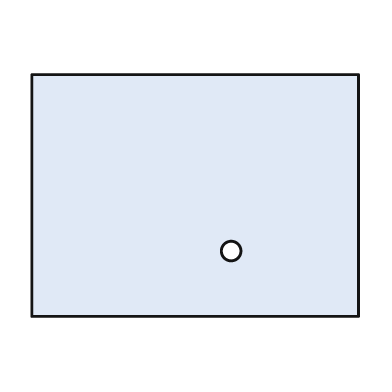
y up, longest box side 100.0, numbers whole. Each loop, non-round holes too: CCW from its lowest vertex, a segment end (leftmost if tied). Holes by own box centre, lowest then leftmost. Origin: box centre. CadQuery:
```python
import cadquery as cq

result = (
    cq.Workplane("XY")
    .moveTo(-50.0, -37.0)
    .lineTo(50.0, -37.0)
    .lineTo(50.0, 37.0)
    .lineTo(-50.0, 37.0)
    .close()
    .moveTo(11.0, -17.0)
    .circle(3.0)
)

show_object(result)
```